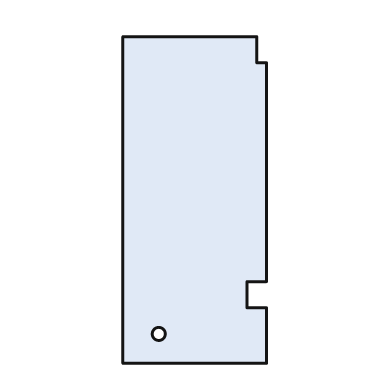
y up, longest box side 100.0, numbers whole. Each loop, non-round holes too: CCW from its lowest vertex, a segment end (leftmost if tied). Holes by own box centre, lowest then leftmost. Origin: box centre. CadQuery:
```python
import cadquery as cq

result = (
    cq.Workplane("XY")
    .moveTo(-22.0, -50.0)
    .lineTo(22.0, -50.0)
    .lineTo(22.0, -33.0)
    .lineTo(16.0, -33.0)
    .lineTo(16.0, -25.0)
    .lineTo(22.0, -25.0)
    .lineTo(22.0, 42.0)
    .lineTo(19.0, 42.0)
    .lineTo(19.0, 50.0)
    .lineTo(-22.0, 50.0)
    .close()
    .moveTo(-11.0, -41.0)
    .circle(2.0)
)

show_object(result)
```